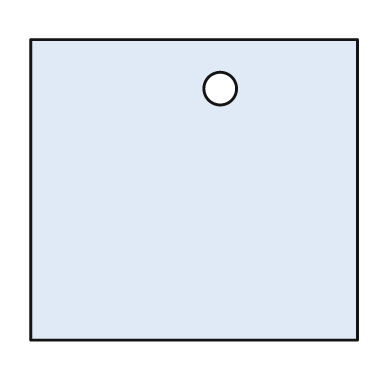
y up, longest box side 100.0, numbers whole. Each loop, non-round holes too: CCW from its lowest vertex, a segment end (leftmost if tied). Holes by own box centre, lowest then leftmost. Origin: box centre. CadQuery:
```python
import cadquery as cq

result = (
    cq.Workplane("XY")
    .moveTo(-50.0, -46.0)
    .lineTo(50.0, -46.0)
    .lineTo(50.0, 46.0)
    .lineTo(-50.0, 46.0)
    .close()
    .moveTo(8.0, 31.0)
    .circle(5.0)
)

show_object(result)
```